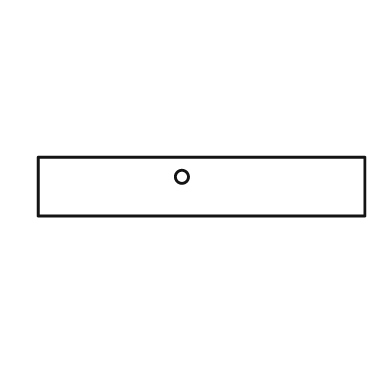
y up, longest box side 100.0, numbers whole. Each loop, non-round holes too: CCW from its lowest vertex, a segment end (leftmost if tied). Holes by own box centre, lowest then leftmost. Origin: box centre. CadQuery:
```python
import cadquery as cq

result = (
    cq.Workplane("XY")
    .moveTo(-50.0, -9.0)
    .lineTo(50.0, -9.0)
    .lineTo(50.0, 9.0)
    .lineTo(-50.0, 9.0)
    .close()
    .moveTo(-6.0, 3.0)
    .circle(2.0)
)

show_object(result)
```